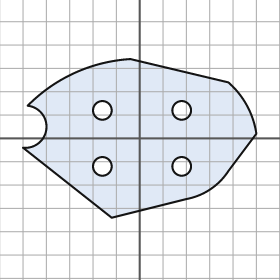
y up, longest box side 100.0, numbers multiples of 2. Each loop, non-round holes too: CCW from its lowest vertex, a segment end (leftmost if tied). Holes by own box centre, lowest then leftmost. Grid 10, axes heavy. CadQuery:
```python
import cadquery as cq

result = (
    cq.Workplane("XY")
    .moveTo(-12.0, -34.0)
    .lineTo(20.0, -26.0)
    .threePointArc((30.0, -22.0), (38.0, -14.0))
    .lineTo(50.0, 2.0)
    .threePointArc((46.0, 14.0), (38.0, 24.0))
    .lineTo(-4.0, 34.0)
    .threePointArc((-28.0, 28.0), (-48.0, 14.0))
    .threePointArc((-40.0, 4.0), (-50.0, -4.0))
    .close()
    .moveTo(-16.0, -12.0)
    .circle(4.0)
    .moveTo(18.0, -12.0)
    .circle(4.0)
    .moveTo(-16.0, 12.0)
    .circle(4.0)
    .moveTo(18.0, 12.0)
    .circle(4.0)
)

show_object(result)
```